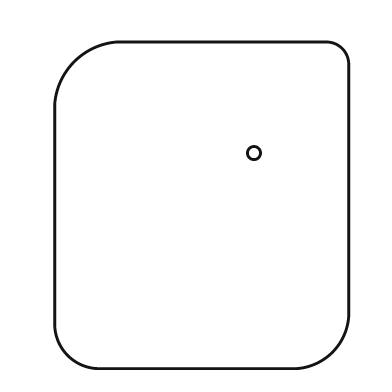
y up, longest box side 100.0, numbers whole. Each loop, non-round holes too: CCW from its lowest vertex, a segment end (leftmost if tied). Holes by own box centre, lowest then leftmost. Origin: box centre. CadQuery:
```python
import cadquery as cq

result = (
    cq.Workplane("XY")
    .moveTo(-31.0, -50.0)
    .lineTo(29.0, -50.0)
    .threePointArc((40.0, -45.0), (45.0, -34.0))
    .lineTo(45.0, 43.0)
    .threePointArc((43.0, 48.0), (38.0, 50.0))
    .lineTo(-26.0, 50.0)
    .threePointArc((-39.0, 44.0), (-45.0, 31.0))
    .lineTo(-45.0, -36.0)
    .threePointArc((-41.0, -46.0), (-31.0, -50.0))
    .close()
    .moveTo(16.0, 16.0)
    .circle(2.0)
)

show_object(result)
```